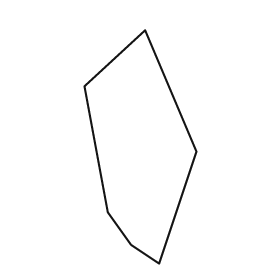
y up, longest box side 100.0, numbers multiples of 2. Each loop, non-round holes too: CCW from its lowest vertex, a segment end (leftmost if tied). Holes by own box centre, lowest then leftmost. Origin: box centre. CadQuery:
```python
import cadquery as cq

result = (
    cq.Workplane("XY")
    .moveTo(8.0, -50.0)
    .lineTo(24.0, -2.0)
    .lineTo(2.0, 50.0)
    .lineTo(-24.0, 26.0)
    .lineTo(-14.0, -28.0)
    .lineTo(-4.0, -42.0)
    .close()
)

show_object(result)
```